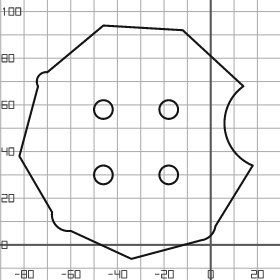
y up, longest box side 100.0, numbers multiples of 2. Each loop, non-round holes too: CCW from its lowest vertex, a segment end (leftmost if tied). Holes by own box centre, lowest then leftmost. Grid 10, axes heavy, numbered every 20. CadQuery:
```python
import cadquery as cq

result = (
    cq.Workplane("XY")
    .moveTo(-34.0, -6.0)
    .lineTo(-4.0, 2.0)
    .threePointArc((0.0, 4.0), (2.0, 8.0))
    .lineTo(18.0, 34.0)
    .threePointArc((6.0, 50.0), (14.0, 68.0))
    .lineTo(-12.0, 92.0)
    .lineTo(-46.0, 94.0)
    .lineTo(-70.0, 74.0)
    .threePointArc((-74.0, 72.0), (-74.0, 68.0))
    .lineTo(-82.0, 38.0)
    .lineTo(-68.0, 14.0)
    .threePointArc((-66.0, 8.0), (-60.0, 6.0))
    .close()
    .moveTo(-46.0, 30.0)
    .circle(4.0)
    .moveTo(-18.0, 30.0)
    .circle(4.0)
    .moveTo(-46.0, 58.0)
    .circle(4.0)
    .moveTo(-18.0, 58.0)
    .circle(4.0)
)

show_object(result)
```